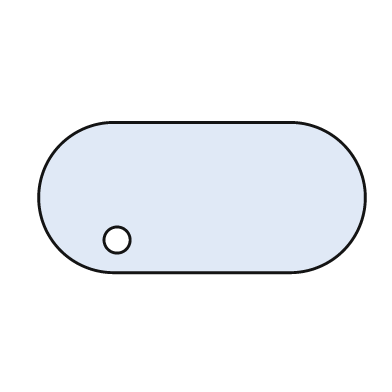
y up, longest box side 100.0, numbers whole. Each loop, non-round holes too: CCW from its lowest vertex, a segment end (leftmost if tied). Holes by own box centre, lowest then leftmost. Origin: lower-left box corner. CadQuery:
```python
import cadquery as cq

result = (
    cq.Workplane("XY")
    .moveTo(23.0, 0.0)
    .lineTo(77.0, 0.0)
    .threePointArc((100.0, 23.0), (77.0, 46.0))
    .lineTo(23.0, 46.0)
    .threePointArc((0.0, 23.0), (23.0, 0.0))
    .close()
    .moveTo(24.0, 10.0)
    .circle(4.0)
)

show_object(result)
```